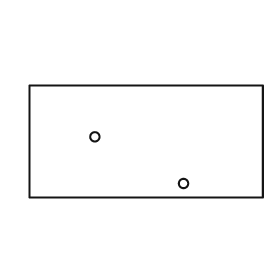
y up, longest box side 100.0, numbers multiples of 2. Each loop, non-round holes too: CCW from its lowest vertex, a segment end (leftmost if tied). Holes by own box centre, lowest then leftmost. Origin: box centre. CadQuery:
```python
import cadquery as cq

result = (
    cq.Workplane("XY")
    .moveTo(-50.0, -24.0)
    .lineTo(50.0, -24.0)
    .lineTo(50.0, 24.0)
    .lineTo(-50.0, 24.0)
    .close()
    .moveTo(16.0, -18.0)
    .circle(2.0)
    .moveTo(-22.0, 2.0)
    .circle(2.0)
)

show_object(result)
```